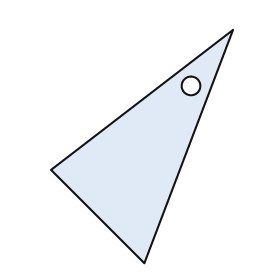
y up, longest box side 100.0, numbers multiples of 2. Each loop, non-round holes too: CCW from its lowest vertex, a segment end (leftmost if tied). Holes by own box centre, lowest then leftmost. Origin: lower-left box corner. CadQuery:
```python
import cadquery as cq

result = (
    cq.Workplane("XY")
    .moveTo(40.0, 0.0)
    .lineTo(78.0, 100.0)
    .lineTo(0.0, 40.0)
    .close()
    .moveTo(60.0, 76.0)
    .circle(4.0)
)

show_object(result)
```